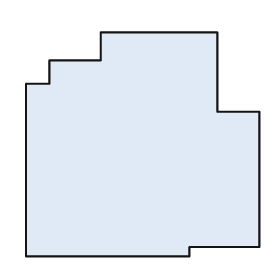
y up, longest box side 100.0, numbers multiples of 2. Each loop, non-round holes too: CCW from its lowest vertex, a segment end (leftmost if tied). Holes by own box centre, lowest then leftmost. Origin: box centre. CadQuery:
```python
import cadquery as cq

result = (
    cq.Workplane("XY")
    .moveTo(-50.0, -48.0)
    .lineTo(20.0, -48.0)
    .lineTo(20.0, -44.0)
    .lineTo(50.0, -44.0)
    .lineTo(50.0, 14.0)
    .lineTo(32.0, 14.0)
    .lineTo(32.0, 48.0)
    .lineTo(-18.0, 48.0)
    .lineTo(-18.0, 36.0)
    .lineTo(-40.0, 36.0)
    .lineTo(-40.0, 26.0)
    .lineTo(-50.0, 26.0)
    .close()
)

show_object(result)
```